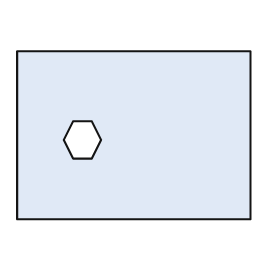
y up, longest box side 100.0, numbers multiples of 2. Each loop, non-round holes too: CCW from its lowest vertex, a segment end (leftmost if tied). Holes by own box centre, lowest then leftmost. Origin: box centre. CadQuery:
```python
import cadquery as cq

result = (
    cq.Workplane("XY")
    .moveTo(-50.0, -36.0)
    .lineTo(50.0, -36.0)
    .lineTo(50.0, 36.0)
    .lineTo(-50.0, 36.0)
    .close()
    .moveTo(-26.0, -10.0)
    .lineTo(-18.0, -10.0)
    .lineTo(-14.0, -2.0)
    .lineTo(-18.0, 6.0)
    .lineTo(-26.0, 6.0)
    .lineTo(-30.0, -2.0)
    .close()
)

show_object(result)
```